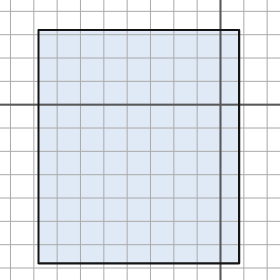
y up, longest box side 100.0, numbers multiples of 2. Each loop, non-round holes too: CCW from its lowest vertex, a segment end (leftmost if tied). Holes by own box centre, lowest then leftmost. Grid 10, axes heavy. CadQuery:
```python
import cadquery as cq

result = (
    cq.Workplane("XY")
    .moveTo(-78.0, -68.0)
    .lineTo(8.0, -68.0)
    .lineTo(8.0, 32.0)
    .lineTo(-78.0, 32.0)
    .close()
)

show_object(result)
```